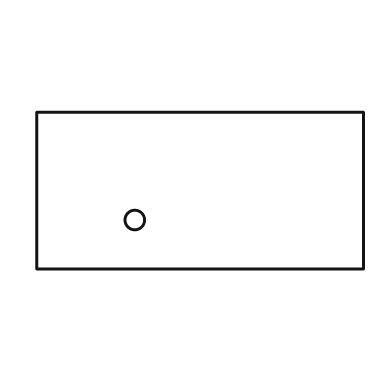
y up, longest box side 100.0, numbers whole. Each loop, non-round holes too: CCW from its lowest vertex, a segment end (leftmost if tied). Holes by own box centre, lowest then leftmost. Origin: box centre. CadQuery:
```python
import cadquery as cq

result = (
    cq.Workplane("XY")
    .moveTo(-50.0, -24.0)
    .lineTo(50.0, -24.0)
    .lineTo(50.0, 24.0)
    .lineTo(-50.0, 24.0)
    .close()
    .moveTo(-20.0, -9.0)
    .circle(3.0)
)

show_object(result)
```